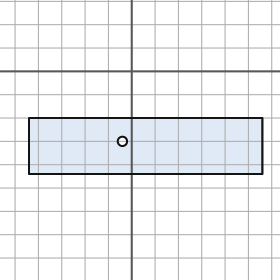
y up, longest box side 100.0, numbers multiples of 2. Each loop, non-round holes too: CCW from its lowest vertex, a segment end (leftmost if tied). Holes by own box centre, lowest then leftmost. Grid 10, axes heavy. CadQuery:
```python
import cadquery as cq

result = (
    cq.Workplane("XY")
    .moveTo(-44.0, -44.0)
    .lineTo(56.0, -44.0)
    .lineTo(56.0, -20.0)
    .lineTo(-44.0, -20.0)
    .close()
    .moveTo(-4.0, -30.0)
    .circle(2.0)
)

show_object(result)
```